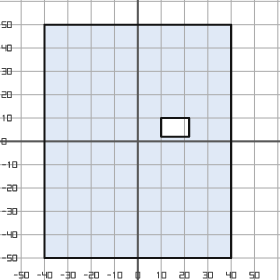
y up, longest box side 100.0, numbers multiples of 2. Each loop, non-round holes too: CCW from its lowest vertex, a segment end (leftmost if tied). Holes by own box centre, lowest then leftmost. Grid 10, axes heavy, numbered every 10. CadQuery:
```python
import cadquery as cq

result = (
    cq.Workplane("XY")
    .moveTo(-40.0, -50.0)
    .lineTo(40.0, -50.0)
    .lineTo(40.0, 50.0)
    .lineTo(-40.0, 50.0)
    .close()
    .moveTo(10.0, 2.0)
    .lineTo(22.0, 2.0)
    .lineTo(22.0, 10.0)
    .lineTo(10.0, 10.0)
    .close()
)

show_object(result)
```